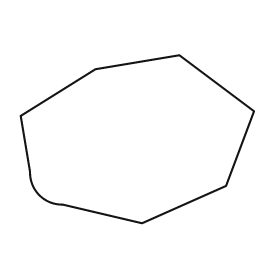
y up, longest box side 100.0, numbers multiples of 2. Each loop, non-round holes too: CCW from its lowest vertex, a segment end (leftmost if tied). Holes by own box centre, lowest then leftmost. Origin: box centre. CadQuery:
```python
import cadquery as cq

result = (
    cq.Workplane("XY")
    .moveTo(2.0, -36.0)
    .lineTo(38.0, -20.0)
    .lineTo(50.0, 12.0)
    .lineTo(18.0, 36.0)
    .lineTo(-18.0, 30.0)
    .lineTo(-50.0, 10.0)
    .lineTo(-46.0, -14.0)
    .threePointArc((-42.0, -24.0), (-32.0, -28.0))
    .close()
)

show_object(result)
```